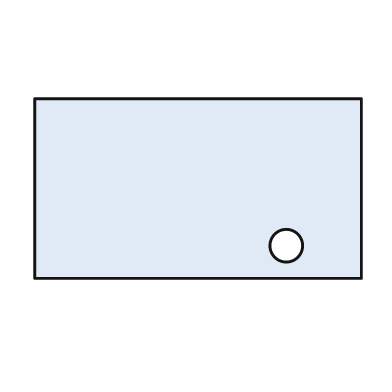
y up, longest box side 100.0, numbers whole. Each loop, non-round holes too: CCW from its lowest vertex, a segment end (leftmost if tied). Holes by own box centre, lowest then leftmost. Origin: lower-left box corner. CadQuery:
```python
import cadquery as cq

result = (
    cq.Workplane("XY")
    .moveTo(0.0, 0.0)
    .lineTo(100.0, 0.0)
    .lineTo(100.0, 55.0)
    .lineTo(0.0, 55.0)
    .close()
    .moveTo(77.0, 10.0)
    .circle(5.0)
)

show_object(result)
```